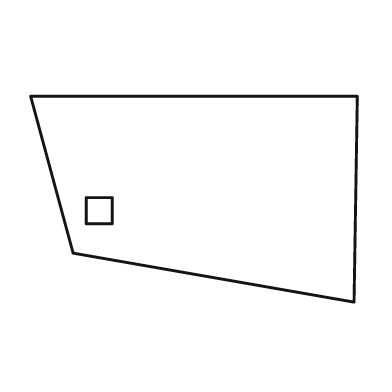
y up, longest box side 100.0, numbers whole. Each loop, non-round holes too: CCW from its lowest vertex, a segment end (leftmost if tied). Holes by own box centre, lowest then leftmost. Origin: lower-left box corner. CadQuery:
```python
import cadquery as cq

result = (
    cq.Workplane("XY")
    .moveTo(99.0, 0.0)
    .lineTo(100.0, 63.0)
    .lineTo(0.0, 63.0)
    .lineTo(13.0, 15.0)
    .close()
    .moveTo(17.0, 24.0)
    .lineTo(25.0, 24.0)
    .lineTo(25.0, 32.0)
    .lineTo(17.0, 32.0)
    .close()
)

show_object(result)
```